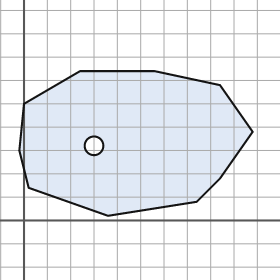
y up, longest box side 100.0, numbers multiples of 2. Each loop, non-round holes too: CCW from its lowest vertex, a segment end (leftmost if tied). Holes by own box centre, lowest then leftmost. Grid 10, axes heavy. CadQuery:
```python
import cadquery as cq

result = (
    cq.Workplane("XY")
    .moveTo(36.0, 2.0)
    .lineTo(74.0, 8.0)
    .lineTo(84.0, 18.0)
    .lineTo(98.0, 38.0)
    .lineTo(84.0, 58.0)
    .lineTo(56.0, 64.0)
    .lineTo(24.0, 64.0)
    .lineTo(0.0, 50.0)
    .lineTo(-2.0, 30.0)
    .lineTo(2.0, 14.0)
    .close()
    .moveTo(30.0, 32.0)
    .circle(4.0)
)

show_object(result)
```